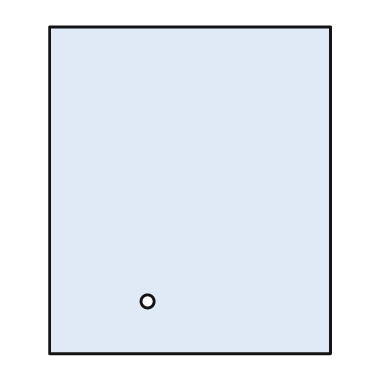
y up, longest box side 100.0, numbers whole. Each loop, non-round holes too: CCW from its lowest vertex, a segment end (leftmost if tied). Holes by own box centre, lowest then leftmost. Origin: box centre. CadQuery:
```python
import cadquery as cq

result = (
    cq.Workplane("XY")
    .moveTo(-43.0, -50.0)
    .lineTo(43.0, -50.0)
    .lineTo(43.0, 50.0)
    .lineTo(-43.0, 50.0)
    .close()
    .moveTo(-13.0, -34.0)
    .circle(2.0)
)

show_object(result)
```